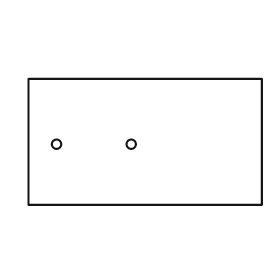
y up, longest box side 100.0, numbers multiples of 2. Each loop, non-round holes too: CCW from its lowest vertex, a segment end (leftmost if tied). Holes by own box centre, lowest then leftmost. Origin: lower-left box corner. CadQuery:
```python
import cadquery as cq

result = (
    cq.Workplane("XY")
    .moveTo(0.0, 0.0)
    .lineTo(100.0, 0.0)
    .lineTo(100.0, 54.0)
    .lineTo(0.0, 54.0)
    .close()
    .moveTo(12.0, 26.0)
    .circle(2.0)
    .moveTo(44.0, 26.0)
    .circle(2.0)
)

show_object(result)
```